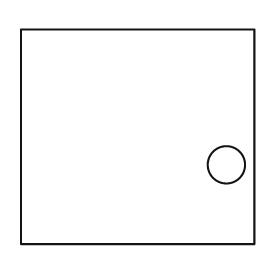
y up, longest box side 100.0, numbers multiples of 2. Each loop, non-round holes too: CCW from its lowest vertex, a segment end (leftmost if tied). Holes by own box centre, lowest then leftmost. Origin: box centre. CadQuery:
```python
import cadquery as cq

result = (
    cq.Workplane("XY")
    .moveTo(-50.0, -46.0)
    .lineTo(50.0, -46.0)
    .lineTo(50.0, 46.0)
    .lineTo(-50.0, 46.0)
    .close()
    .moveTo(38.0, -12.0)
    .circle(8.0)
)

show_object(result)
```